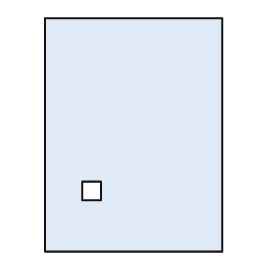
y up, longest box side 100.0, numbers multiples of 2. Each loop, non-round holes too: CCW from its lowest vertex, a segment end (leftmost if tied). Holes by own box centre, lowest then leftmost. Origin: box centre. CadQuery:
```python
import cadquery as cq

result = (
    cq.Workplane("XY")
    .moveTo(-38.0, -50.0)
    .lineTo(38.0, -50.0)
    .lineTo(38.0, 50.0)
    .lineTo(-38.0, 50.0)
    .close()
    .moveTo(-22.0, -28.0)
    .lineTo(-14.0, -28.0)
    .lineTo(-14.0, -20.0)
    .lineTo(-22.0, -20.0)
    .close()
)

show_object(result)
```